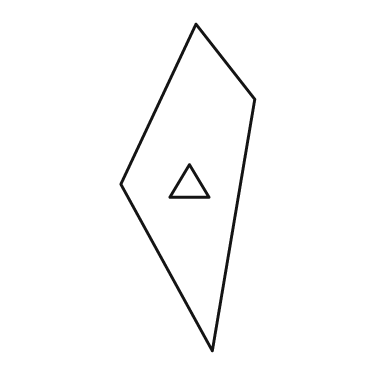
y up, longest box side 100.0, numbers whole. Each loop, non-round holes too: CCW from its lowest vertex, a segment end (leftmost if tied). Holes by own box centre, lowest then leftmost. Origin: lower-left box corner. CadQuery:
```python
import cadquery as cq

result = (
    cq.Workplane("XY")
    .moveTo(28.0, 0.0)
    .lineTo(41.0, 77.0)
    .lineTo(23.0, 100.0)
    .lineTo(0.0, 51.0)
    .close()
    .moveTo(15.0, 47.0)
    .lineTo(27.0, 47.0)
    .lineTo(21.0, 57.0)
    .close()
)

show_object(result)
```